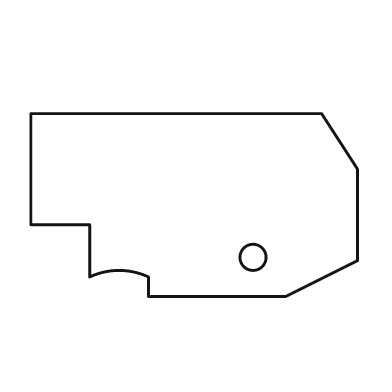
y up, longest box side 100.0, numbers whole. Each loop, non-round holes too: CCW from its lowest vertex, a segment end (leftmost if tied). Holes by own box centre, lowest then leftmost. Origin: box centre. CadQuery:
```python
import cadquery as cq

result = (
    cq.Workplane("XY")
    .moveTo(-14.0, -28.0)
    .lineTo(28.0, -28.0)
    .lineTo(50.0, -17.0)
    .lineTo(50.0, 11.0)
    .lineTo(39.0, 28.0)
    .lineTo(-50.0, 28.0)
    .lineTo(-50.0, -6.0)
    .lineTo(-32.0, -6.0)
    .lineTo(-32.0, -22.0)
    .threePointArc((-23.0, -20.0), (-14.0, -22.0))
    .close()
    .moveTo(18.0, -16.0)
    .circle(4.0)
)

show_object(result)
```